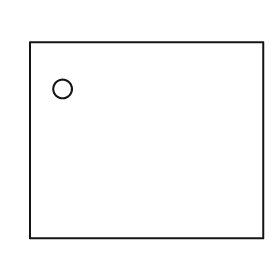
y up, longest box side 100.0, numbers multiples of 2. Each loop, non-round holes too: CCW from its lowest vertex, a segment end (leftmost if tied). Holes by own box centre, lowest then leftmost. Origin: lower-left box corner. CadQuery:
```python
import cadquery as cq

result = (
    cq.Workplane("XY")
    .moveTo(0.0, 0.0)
    .lineTo(100.0, 0.0)
    .lineTo(100.0, 84.0)
    .lineTo(0.0, 84.0)
    .close()
    .moveTo(14.0, 64.0)
    .circle(4.0)
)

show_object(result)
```